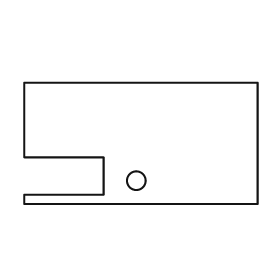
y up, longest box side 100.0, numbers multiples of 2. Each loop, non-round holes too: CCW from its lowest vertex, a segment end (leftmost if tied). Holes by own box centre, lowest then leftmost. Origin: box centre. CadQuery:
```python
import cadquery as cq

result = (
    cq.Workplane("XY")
    .moveTo(-50.0, -26.0)
    .lineTo(50.0, -26.0)
    .lineTo(50.0, 26.0)
    .lineTo(-50.0, 26.0)
    .lineTo(-50.0, -6.0)
    .lineTo(-16.0, -6.0)
    .lineTo(-16.0, -22.0)
    .lineTo(-50.0, -22.0)
    .close()
    .moveTo(-2.0, -16.0)
    .circle(4.0)
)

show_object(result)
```